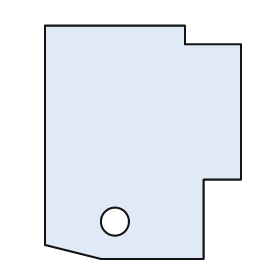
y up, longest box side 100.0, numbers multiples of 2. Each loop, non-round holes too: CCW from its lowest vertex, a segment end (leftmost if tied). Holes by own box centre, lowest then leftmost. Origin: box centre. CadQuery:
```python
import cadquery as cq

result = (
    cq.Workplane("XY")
    .moveTo(-18.0, -50.0)
    .lineTo(26.0, -50.0)
    .lineTo(26.0, -16.0)
    .lineTo(42.0, -16.0)
    .lineTo(42.0, 42.0)
    .lineTo(18.0, 42.0)
    .lineTo(18.0, 50.0)
    .lineTo(-42.0, 50.0)
    .lineTo(-42.0, -44.0)
    .close()
    .moveTo(-12.0, -34.0)
    .circle(6.0)
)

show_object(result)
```